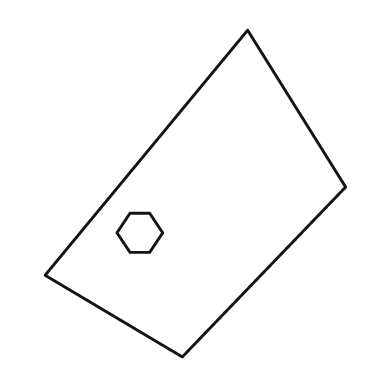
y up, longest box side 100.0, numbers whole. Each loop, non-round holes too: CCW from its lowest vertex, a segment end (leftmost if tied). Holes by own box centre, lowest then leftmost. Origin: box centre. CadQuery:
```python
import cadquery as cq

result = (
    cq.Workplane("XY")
    .moveTo(-4.0, -50.0)
    .lineTo(46.0, 2.0)
    .lineTo(16.0, 50.0)
    .lineTo(-46.0, -25.0)
    .close()
    .moveTo(-20.0, -18.0)
    .lineTo(-14.0, -18.0)
    .lineTo(-10.0, -12.0)
    .lineTo(-14.0, -6.0)
    .lineTo(-20.0, -6.0)
    .lineTo(-24.0, -12.0)
    .close()
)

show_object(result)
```